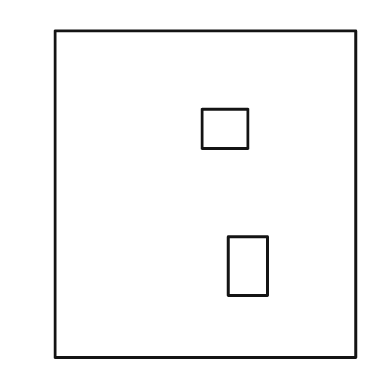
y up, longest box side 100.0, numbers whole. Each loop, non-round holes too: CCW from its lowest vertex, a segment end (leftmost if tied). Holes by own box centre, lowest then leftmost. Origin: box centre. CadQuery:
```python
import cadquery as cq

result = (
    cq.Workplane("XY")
    .moveTo(-46.0, -50.0)
    .lineTo(46.0, -50.0)
    .lineTo(46.0, 50.0)
    .lineTo(-46.0, 50.0)
    .close()
    .moveTo(7.0, -31.0)
    .lineTo(19.0, -31.0)
    .lineTo(19.0, -13.0)
    .lineTo(7.0, -13.0)
    .close()
    .moveTo(-1.0, 14.0)
    .lineTo(13.0, 14.0)
    .lineTo(13.0, 26.0)
    .lineTo(-1.0, 26.0)
    .close()
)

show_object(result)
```